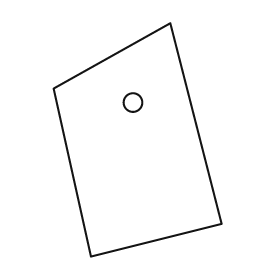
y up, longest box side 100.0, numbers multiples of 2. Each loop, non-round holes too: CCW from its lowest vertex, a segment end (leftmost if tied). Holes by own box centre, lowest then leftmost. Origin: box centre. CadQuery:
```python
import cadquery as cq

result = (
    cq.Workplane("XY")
    .moveTo(-20.0, -50.0)
    .lineTo(36.0, -36.0)
    .lineTo(14.0, 50.0)
    .lineTo(-36.0, 22.0)
    .close()
    .moveTo(-2.0, 16.0)
    .circle(4.0)
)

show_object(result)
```